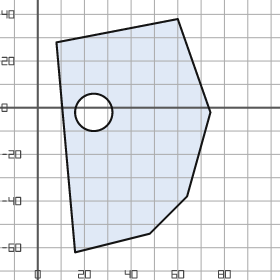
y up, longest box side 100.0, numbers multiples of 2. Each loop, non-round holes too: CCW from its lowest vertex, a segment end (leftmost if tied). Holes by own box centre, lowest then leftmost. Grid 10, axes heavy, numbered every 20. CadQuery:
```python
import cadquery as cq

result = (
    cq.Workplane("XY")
    .moveTo(16.0, -62.0)
    .lineTo(48.0, -54.0)
    .lineTo(64.0, -38.0)
    .lineTo(74.0, -2.0)
    .lineTo(60.0, 38.0)
    .lineTo(8.0, 28.0)
    .close()
    .moveTo(24.0, -2.0)
    .circle(8.0)
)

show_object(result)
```